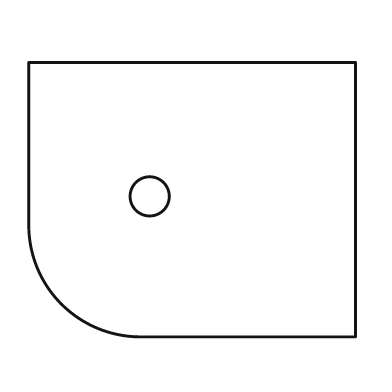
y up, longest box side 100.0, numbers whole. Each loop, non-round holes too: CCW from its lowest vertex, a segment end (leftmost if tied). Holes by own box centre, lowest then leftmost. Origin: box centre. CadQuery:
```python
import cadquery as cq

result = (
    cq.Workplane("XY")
    .moveTo(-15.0, -42.0)
    .lineTo(50.0, -42.0)
    .lineTo(50.0, 42.0)
    .lineTo(-50.0, 42.0)
    .lineTo(-50.0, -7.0)
    .threePointArc((-40.0, -32.0), (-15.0, -42.0))
    .close()
    .moveTo(-13.0, 1.0)
    .circle(6.0)
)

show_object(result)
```